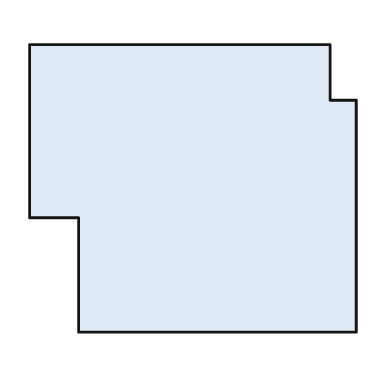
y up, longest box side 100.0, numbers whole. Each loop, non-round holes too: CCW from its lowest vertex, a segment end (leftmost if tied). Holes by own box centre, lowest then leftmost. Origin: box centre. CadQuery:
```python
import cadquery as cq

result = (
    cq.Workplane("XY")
    .moveTo(-35.0, -44.0)
    .lineTo(50.0, -44.0)
    .lineTo(50.0, 27.0)
    .lineTo(42.0, 27.0)
    .lineTo(42.0, 44.0)
    .lineTo(-50.0, 44.0)
    .lineTo(-50.0, -9.0)
    .lineTo(-35.0, -9.0)
    .close()
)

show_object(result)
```